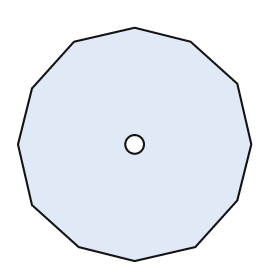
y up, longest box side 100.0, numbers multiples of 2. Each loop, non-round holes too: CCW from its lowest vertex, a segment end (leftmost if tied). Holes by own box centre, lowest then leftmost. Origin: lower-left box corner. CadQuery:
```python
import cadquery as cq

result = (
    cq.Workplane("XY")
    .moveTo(50.0, 0.0)
    .lineTo(76.0, 6.0)
    .lineTo(94.0, 26.0)
    .lineTo(100.0, 50.0)
    .lineTo(94.0, 76.0)
    .lineTo(74.0, 94.0)
    .lineTo(50.0, 100.0)
    .lineTo(24.0, 94.0)
    .lineTo(6.0, 74.0)
    .lineTo(0.0, 50.0)
    .lineTo(6.0, 24.0)
    .lineTo(26.0, 6.0)
    .close()
    .moveTo(50.0, 50.0)
    .circle(4.0)
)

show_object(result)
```